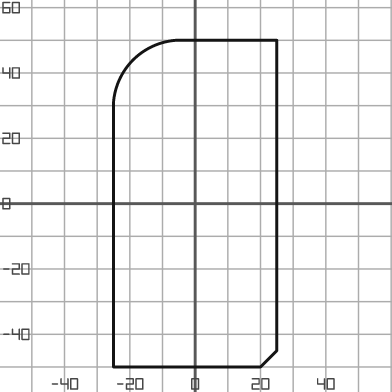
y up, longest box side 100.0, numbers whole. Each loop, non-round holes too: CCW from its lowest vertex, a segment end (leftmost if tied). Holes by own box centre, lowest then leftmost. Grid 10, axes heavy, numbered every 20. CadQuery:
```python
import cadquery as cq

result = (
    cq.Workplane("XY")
    .moveTo(-25.0, -50.0)
    .lineTo(20.0, -50.0)
    .lineTo(25.0, -45.0)
    .lineTo(25.0, 50.0)
    .lineTo(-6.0, 50.0)
    .threePointArc((-19.0, 44.0), (-25.0, 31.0))
    .close()
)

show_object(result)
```